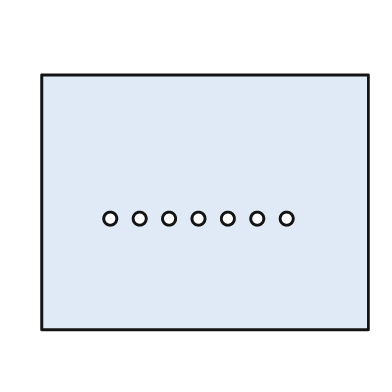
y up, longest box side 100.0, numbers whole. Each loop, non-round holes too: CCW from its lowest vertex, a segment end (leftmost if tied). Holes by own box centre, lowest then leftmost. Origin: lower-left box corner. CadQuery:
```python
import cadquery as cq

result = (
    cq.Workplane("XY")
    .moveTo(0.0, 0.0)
    .lineTo(100.0, 0.0)
    .lineTo(100.0, 78.0)
    .lineTo(0.0, 78.0)
    .close()
    .moveTo(21.0, 34.0)
    .circle(2.0)
    .moveTo(30.0, 34.0)
    .circle(2.0)
    .moveTo(39.0, 34.0)
    .circle(2.0)
    .moveTo(48.0, 34.0)
    .circle(2.0)
    .moveTo(57.0, 34.0)
    .circle(2.0)
    .moveTo(66.0, 34.0)
    .circle(2.0)
    .moveTo(75.0, 34.0)
    .circle(2.0)
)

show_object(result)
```